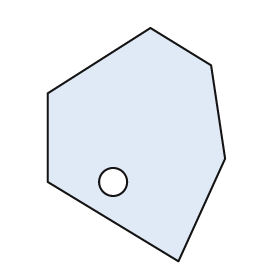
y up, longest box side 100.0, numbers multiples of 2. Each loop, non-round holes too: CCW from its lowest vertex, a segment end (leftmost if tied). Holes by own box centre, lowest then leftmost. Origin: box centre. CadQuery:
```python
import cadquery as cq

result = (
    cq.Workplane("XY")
    .moveTo(18.0, -50.0)
    .lineTo(38.0, -6.0)
    .lineTo(32.0, 34.0)
    .lineTo(6.0, 50.0)
    .lineTo(-38.0, 22.0)
    .lineTo(-38.0, -16.0)
    .close()
    .moveTo(-10.0, -16.0)
    .circle(6.0)
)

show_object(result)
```